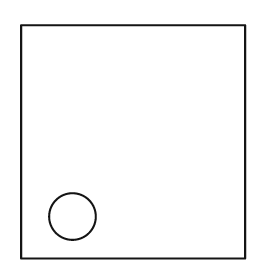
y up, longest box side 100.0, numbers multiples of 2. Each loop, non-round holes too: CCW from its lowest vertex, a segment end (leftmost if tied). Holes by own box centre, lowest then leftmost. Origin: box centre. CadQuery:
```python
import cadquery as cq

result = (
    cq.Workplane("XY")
    .moveTo(-48.0, -50.0)
    .lineTo(48.0, -50.0)
    .lineTo(48.0, 50.0)
    .lineTo(-48.0, 50.0)
    .close()
    .moveTo(-26.0, -32.0)
    .circle(10.0)
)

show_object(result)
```